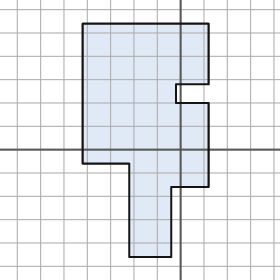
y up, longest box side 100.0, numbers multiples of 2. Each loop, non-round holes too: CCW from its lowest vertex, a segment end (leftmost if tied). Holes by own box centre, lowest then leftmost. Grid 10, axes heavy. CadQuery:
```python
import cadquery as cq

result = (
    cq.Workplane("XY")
    .moveTo(-22.0, -46.0)
    .lineTo(-4.0, -46.0)
    .lineTo(-4.0, -16.0)
    .lineTo(12.0, -16.0)
    .lineTo(12.0, 20.0)
    .lineTo(-2.0, 20.0)
    .lineTo(-2.0, 28.0)
    .lineTo(12.0, 28.0)
    .lineTo(12.0, 54.0)
    .lineTo(-42.0, 54.0)
    .lineTo(-42.0, -6.0)
    .lineTo(-22.0, -6.0)
    .close()
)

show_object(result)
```